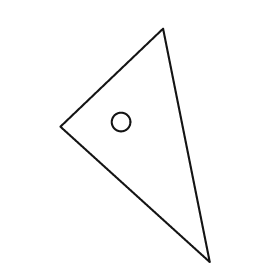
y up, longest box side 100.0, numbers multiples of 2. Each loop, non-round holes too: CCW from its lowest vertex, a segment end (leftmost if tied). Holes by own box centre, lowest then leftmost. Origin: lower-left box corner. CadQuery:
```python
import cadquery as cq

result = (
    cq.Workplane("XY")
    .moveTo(64.0, 0.0)
    .lineTo(44.0, 100.0)
    .lineTo(0.0, 58.0)
    .close()
    .moveTo(26.0, 60.0)
    .circle(4.0)
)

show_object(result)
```